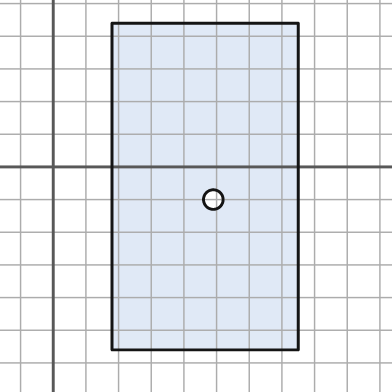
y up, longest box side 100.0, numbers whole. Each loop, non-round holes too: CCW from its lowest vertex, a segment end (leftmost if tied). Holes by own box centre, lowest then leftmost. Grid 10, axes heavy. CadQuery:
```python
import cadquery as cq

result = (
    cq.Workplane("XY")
    .moveTo(18.0, -56.0)
    .lineTo(75.0, -56.0)
    .lineTo(75.0, 44.0)
    .lineTo(18.0, 44.0)
    .close()
    .moveTo(49.0, -10.0)
    .circle(3.0)
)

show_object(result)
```